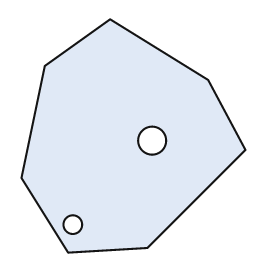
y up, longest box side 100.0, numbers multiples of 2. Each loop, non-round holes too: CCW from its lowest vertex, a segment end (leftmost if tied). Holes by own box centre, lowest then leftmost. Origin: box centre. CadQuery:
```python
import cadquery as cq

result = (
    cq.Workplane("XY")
    .moveTo(-28.0, -50.0)
    .lineTo(6.0, -48.0)
    .lineTo(48.0, -6.0)
    .lineTo(32.0, 24.0)
    .lineTo(-10.0, 50.0)
    .lineTo(-38.0, 30.0)
    .lineTo(-48.0, -18.0)
    .close()
    .moveTo(-26.0, -38.0)
    .circle(4.0)
    .moveTo(8.0, -2.0)
    .circle(6.0)
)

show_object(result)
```